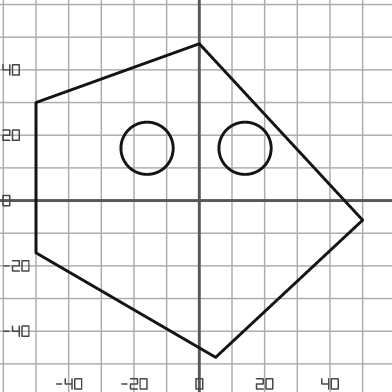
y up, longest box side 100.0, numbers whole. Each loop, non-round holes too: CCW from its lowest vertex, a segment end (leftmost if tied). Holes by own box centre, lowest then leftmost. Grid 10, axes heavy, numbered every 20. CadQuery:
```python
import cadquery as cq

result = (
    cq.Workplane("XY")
    .moveTo(5.0, -48.0)
    .lineTo(50.0, -6.0)
    .lineTo(0.0, 48.0)
    .lineTo(-50.0, 30.0)
    .lineTo(-50.0, -16.0)
    .close()
    .moveTo(-16.0, 16.0)
    .circle(8.0)
    .moveTo(14.0, 16.0)
    .circle(8.0)
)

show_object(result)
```